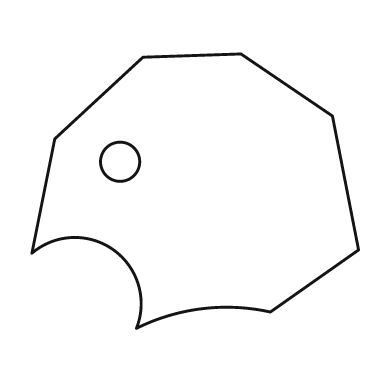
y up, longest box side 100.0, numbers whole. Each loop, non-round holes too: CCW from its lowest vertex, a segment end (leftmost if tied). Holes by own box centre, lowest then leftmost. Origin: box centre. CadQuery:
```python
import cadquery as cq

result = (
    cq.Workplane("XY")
    .moveTo(-18.0, -42.0)
    .threePointArc((2.0, -36.0), (23.0, -37.0))
    .lineTo(50.0, -18.0)
    .lineTo(42.0, 23.0)
    .lineTo(14.0, 42.0)
    .lineTo(-16.0, 41.0)
    .lineTo(-43.0, 16.0)
    .lineTo(-50.0, -19.0)
    .threePointArc((-25.0, -18.0), (-18.0, -42.0))
    .close()
    .moveTo(-23.0, 9.0)
    .circle(6.0)
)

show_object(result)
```